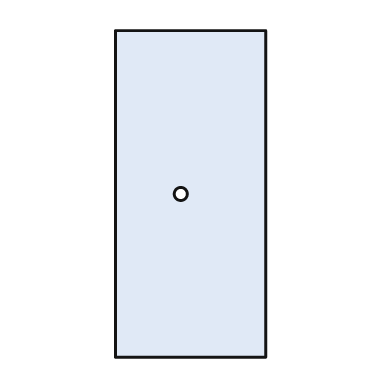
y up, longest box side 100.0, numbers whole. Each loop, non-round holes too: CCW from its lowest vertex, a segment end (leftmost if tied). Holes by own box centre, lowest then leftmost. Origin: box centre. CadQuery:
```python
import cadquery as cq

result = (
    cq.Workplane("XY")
    .moveTo(-23.0, -50.0)
    .lineTo(23.0, -50.0)
    .lineTo(23.0, 50.0)
    .lineTo(-23.0, 50.0)
    .close()
    .moveTo(-3.0, 0.0)
    .circle(2.0)
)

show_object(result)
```